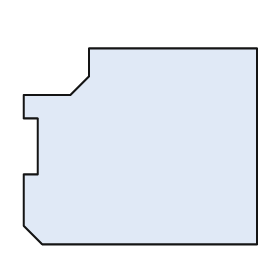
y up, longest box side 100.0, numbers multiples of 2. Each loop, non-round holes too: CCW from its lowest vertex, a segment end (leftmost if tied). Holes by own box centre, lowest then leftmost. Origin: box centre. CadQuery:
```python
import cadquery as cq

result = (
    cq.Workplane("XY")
    .moveTo(-42.0, -42.0)
    .lineTo(50.0, -42.0)
    .lineTo(50.0, 42.0)
    .lineTo(-22.0, 42.0)
    .lineTo(-22.0, 30.0)
    .lineTo(-30.0, 22.0)
    .lineTo(-50.0, 22.0)
    .lineTo(-50.0, 12.0)
    .lineTo(-44.0, 12.0)
    .lineTo(-44.0, -12.0)
    .lineTo(-50.0, -12.0)
    .lineTo(-50.0, -34.0)
    .close()
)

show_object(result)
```